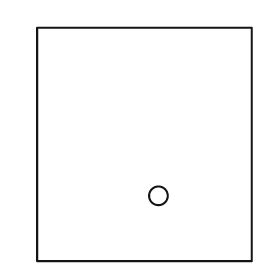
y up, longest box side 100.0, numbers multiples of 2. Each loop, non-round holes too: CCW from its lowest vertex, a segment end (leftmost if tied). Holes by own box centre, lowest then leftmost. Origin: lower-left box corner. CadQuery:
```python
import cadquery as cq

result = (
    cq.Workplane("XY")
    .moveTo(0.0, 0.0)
    .lineTo(92.0, 0.0)
    .lineTo(92.0, 100.0)
    .lineTo(0.0, 100.0)
    .close()
    .moveTo(52.0, 28.0)
    .circle(4.0)
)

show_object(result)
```